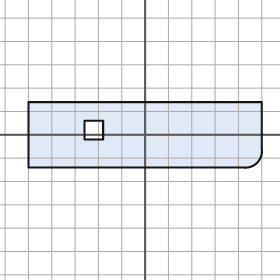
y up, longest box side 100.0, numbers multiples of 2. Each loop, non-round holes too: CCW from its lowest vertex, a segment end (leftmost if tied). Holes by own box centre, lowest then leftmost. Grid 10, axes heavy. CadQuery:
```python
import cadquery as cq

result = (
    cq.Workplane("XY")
    .moveTo(-50.0, -14.0)
    .lineTo(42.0, -14.0)
    .threePointArc((48.0, -12.0), (50.0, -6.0))
    .lineTo(50.0, 14.0)
    .lineTo(-50.0, 14.0)
    .close()
    .moveTo(-26.0, -2.0)
    .lineTo(-18.0, -2.0)
    .lineTo(-18.0, 6.0)
    .lineTo(-26.0, 6.0)
    .close()
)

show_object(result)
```